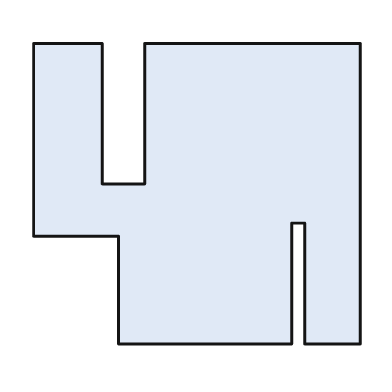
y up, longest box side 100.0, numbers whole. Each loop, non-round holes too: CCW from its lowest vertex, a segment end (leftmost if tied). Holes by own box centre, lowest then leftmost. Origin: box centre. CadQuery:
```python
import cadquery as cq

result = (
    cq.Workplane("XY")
    .moveTo(-24.0, -46.0)
    .lineTo(29.0, -46.0)
    .lineTo(29.0, -9.0)
    .lineTo(33.0, -9.0)
    .lineTo(33.0, -46.0)
    .lineTo(50.0, -46.0)
    .lineTo(50.0, 46.0)
    .lineTo(-16.0, 46.0)
    .lineTo(-16.0, 3.0)
    .lineTo(-29.0, 3.0)
    .lineTo(-29.0, 46.0)
    .lineTo(-50.0, 46.0)
    .lineTo(-50.0, -13.0)
    .lineTo(-24.0, -13.0)
    .close()
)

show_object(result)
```